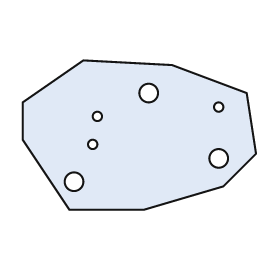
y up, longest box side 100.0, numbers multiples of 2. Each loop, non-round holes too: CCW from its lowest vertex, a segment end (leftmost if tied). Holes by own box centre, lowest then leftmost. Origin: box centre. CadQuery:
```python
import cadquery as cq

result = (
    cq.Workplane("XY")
    .moveTo(-30.0, -32.0)
    .lineTo(2.0, -32.0)
    .lineTo(36.0, -22.0)
    .lineTo(50.0, -8.0)
    .lineTo(46.0, 18.0)
    .lineTo(14.0, 30.0)
    .lineTo(-24.0, 32.0)
    .lineTo(-50.0, 14.0)
    .lineTo(-50.0, -2.0)
    .close()
    .moveTo(-28.0, -20.0)
    .circle(4.0)
    .moveTo(34.0, -10.0)
    .circle(4.0)
    .moveTo(-20.0, -4.0)
    .circle(2.0)
    .moveTo(-18.0, 8.0)
    .circle(2.0)
    .moveTo(34.0, 12.0)
    .circle(2.0)
    .moveTo(4.0, 18.0)
    .circle(4.0)
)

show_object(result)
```